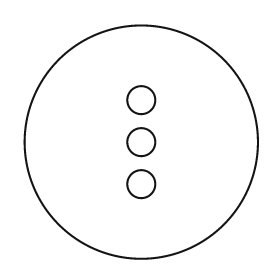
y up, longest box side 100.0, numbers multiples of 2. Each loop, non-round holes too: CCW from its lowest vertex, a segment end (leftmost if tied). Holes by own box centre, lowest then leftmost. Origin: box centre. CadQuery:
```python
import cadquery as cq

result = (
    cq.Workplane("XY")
    .moveTo(0.0, 0.0)
    .circle(50.0)
    .moveTo(0.0, -18.0)
    .circle(6.0)
    .moveTo(0.0, 0.0)
    .circle(6.0)
    .moveTo(0.0, 18.0)
    .circle(6.0)
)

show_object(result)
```